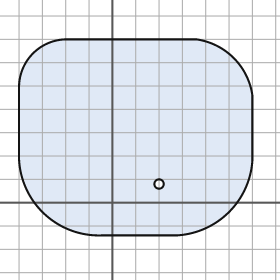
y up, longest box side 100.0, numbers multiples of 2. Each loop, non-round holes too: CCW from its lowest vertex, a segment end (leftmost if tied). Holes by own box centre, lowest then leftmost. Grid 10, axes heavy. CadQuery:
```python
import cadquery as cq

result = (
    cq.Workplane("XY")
    .moveTo(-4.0, -14.0)
    .lineTo(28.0, -14.0)
    .threePointArc((50.0, -4.0), (60.0, 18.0))
    .lineTo(60.0, 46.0)
    .threePointArc((52.0, 62.0), (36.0, 70.0))
    .lineTo(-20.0, 70.0)
    .threePointArc((-34.0, 64.0), (-40.0, 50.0))
    .lineTo(-40.0, 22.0)
    .threePointArc((-30.0, -4.0), (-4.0, -14.0))
    .close()
    .moveTo(20.0, 8.0)
    .circle(2.0)
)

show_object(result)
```